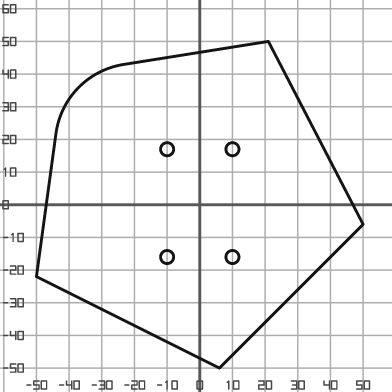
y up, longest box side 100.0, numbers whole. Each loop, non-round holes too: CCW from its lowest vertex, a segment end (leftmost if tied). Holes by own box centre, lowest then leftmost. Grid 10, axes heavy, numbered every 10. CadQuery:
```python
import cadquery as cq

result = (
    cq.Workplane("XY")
    .moveTo(6.0, -50.0)
    .lineTo(50.0, -6.0)
    .lineTo(21.0, 50.0)
    .lineTo(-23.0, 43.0)
    .threePointArc((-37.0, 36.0), (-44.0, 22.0))
    .lineTo(-50.0, -22.0)
    .close()
    .moveTo(-10.0, -16.0)
    .circle(2.0)
    .moveTo(10.0, -16.0)
    .circle(2.0)
    .moveTo(-10.0, 17.0)
    .circle(2.0)
    .moveTo(10.0, 17.0)
    .circle(2.0)
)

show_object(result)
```